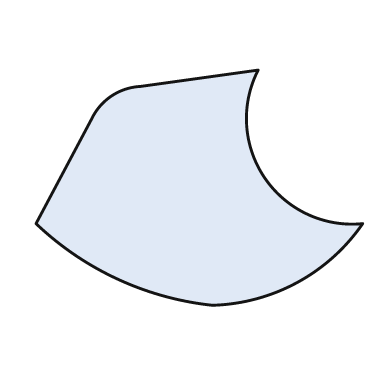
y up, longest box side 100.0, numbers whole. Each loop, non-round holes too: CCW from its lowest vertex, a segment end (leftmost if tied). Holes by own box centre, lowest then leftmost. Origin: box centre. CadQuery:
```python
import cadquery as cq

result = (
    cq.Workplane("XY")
    .moveTo(4.0, -36.0)
    .threePointArc((30.0, -29.0), (50.0, -11.0))
    .threePointArc((20.0, 3.0), (18.0, 36.0))
    .lineTo(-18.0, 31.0)
    .threePointArc((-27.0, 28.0), (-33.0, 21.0))
    .lineTo(-50.0, -11.0)
    .threePointArc((-25.0, -28.0), (4.0, -36.0))
    .close()
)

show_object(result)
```